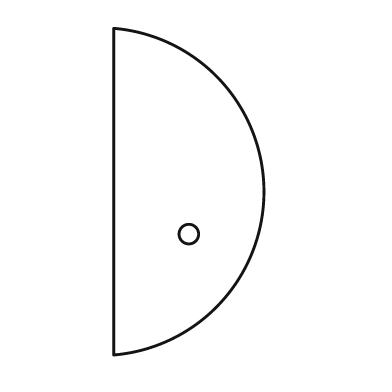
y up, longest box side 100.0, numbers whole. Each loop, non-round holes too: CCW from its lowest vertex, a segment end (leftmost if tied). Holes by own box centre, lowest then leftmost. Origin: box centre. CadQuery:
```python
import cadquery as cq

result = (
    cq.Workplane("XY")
    .moveTo(-23.0, -50.0)
    .threePointArc((23.0, 0.0), (-23.0, 50.0))
    .close()
    .moveTo(0.0, -13.0)
    .circle(3.0)
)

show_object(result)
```